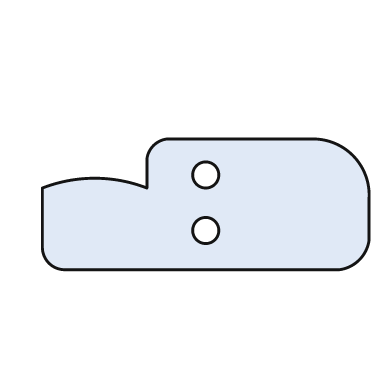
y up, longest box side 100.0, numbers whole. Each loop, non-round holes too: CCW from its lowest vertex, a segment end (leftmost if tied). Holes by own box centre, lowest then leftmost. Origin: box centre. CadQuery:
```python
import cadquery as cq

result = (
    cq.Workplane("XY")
    .moveTo(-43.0, -20.0)
    .lineTo(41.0, -20.0)
    .threePointArc((47.0, -17.0), (50.0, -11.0))
    .lineTo(50.0, 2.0)
    .threePointArc((45.0, 15.0), (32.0, 20.0))
    .lineTo(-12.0, 20.0)
    .threePointArc((-16.0, 18.0), (-18.0, 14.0))
    .lineTo(-18.0, 5.0)
    .threePointArc((-34.0, 8.0), (-50.0, 5.0))
    .lineTo(-50.0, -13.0)
    .threePointArc((-48.0, -18.0), (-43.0, -20.0))
    .close()
    .moveTo(0.0, -8.0)
    .circle(4.0)
    .moveTo(0.0, 9.0)
    .circle(4.0)
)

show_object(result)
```